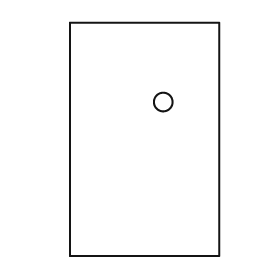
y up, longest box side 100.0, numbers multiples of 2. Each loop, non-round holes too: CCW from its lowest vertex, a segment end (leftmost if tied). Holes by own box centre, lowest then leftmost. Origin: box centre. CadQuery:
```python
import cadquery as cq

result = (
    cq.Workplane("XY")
    .moveTo(-32.0, -50.0)
    .lineTo(32.0, -50.0)
    .lineTo(32.0, 50.0)
    .lineTo(-32.0, 50.0)
    .close()
    .moveTo(8.0, 16.0)
    .circle(4.0)
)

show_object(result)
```